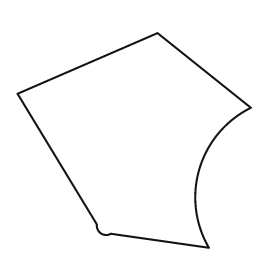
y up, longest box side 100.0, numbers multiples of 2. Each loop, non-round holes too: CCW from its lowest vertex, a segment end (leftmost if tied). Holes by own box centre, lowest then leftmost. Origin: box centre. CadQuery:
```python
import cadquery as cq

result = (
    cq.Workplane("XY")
    .moveTo(32.0, -46.0)
    .threePointArc((28.0, -12.0), (50.0, 14.0))
    .lineTo(10.0, 46.0)
    .lineTo(-50.0, 20.0)
    .lineTo(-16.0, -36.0)
    .threePointArc((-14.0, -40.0), (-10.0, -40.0))
    .close()
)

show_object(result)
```